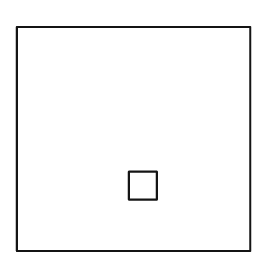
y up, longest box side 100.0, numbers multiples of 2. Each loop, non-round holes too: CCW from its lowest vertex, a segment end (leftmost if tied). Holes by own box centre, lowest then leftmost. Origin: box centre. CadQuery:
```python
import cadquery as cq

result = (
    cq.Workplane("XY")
    .moveTo(-50.0, -48.0)
    .lineTo(50.0, -48.0)
    .lineTo(50.0, 48.0)
    .lineTo(-50.0, 48.0)
    .close()
    .moveTo(-2.0, -26.0)
    .lineTo(10.0, -26.0)
    .lineTo(10.0, -14.0)
    .lineTo(-2.0, -14.0)
    .close()
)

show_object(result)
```